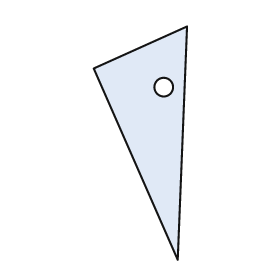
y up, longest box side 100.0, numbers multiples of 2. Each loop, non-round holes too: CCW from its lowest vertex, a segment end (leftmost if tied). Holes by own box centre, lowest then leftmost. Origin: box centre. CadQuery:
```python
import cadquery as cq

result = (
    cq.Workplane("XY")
    .moveTo(16.0, -50.0)
    .lineTo(20.0, 50.0)
    .lineTo(-20.0, 32.0)
    .close()
    .moveTo(10.0, 24.0)
    .circle(4.0)
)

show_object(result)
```